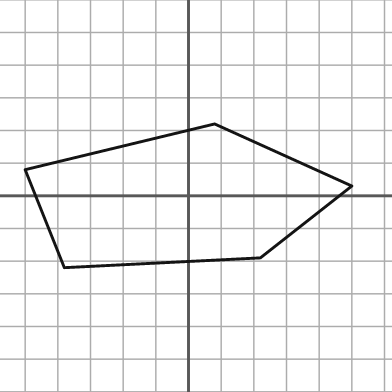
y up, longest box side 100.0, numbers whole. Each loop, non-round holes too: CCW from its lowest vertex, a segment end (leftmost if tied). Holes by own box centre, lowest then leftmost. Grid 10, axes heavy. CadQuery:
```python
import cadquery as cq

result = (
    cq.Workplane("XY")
    .moveTo(-38.0, -22.0)
    .lineTo(22.0, -19.0)
    .lineTo(50.0, 3.0)
    .lineTo(8.0, 22.0)
    .lineTo(-50.0, 8.0)
    .close()
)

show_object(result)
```